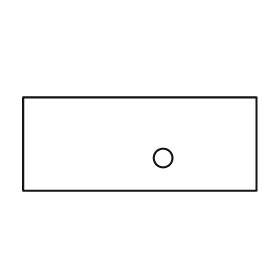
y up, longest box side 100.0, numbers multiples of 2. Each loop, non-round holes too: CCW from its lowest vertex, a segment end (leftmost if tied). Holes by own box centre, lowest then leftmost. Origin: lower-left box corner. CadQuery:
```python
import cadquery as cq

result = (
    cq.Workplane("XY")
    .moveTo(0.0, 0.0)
    .lineTo(100.0, 0.0)
    .lineTo(100.0, 40.0)
    .lineTo(0.0, 40.0)
    .close()
    .moveTo(60.0, 14.0)
    .circle(4.0)
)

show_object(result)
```